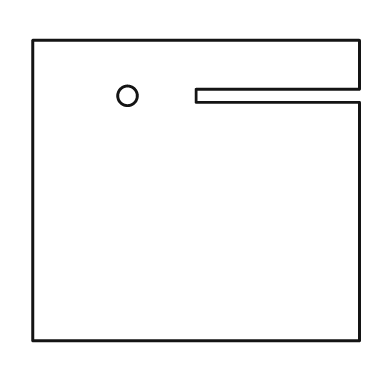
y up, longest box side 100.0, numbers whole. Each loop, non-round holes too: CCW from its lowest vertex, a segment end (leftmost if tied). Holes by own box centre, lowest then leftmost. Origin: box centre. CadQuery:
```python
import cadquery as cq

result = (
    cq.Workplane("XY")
    .moveTo(-50.0, -46.0)
    .lineTo(50.0, -46.0)
    .lineTo(50.0, 27.0)
    .lineTo(0.0, 27.0)
    .lineTo(0.0, 31.0)
    .lineTo(50.0, 31.0)
    .lineTo(50.0, 46.0)
    .lineTo(-50.0, 46.0)
    .close()
    .moveTo(-21.0, 29.0)
    .circle(3.0)
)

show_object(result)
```